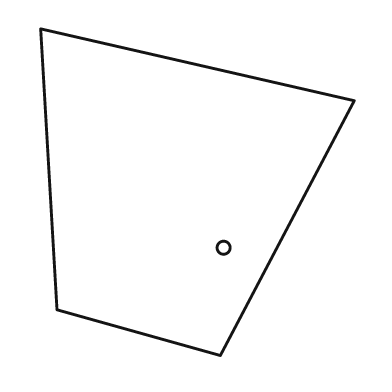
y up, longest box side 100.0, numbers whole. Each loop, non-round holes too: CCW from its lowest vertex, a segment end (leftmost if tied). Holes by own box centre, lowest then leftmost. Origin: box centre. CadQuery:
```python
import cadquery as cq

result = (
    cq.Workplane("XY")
    .moveTo(7.0, -50.0)
    .lineTo(48.0, 28.0)
    .lineTo(-48.0, 50.0)
    .lineTo(-43.0, -36.0)
    .close()
    .moveTo(8.0, -17.0)
    .circle(2.0)
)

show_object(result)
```